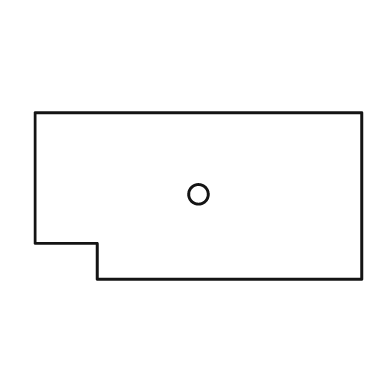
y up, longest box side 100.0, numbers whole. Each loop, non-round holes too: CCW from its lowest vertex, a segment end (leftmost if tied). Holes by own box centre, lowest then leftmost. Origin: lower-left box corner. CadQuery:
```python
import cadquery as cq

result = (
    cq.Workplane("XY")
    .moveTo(19.0, 0.0)
    .lineTo(100.0, 0.0)
    .lineTo(100.0, 51.0)
    .lineTo(0.0, 51.0)
    .lineTo(0.0, 11.0)
    .lineTo(19.0, 11.0)
    .close()
    .moveTo(50.0, 26.0)
    .circle(3.0)
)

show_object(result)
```